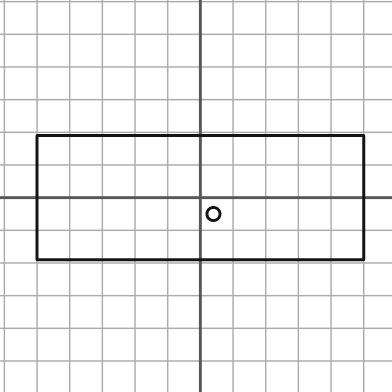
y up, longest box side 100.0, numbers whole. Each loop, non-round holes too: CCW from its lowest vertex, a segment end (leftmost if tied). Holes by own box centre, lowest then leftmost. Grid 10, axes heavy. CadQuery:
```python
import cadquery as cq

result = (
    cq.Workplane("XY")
    .moveTo(-50.0, -19.0)
    .lineTo(50.0, -19.0)
    .lineTo(50.0, 19.0)
    .lineTo(-50.0, 19.0)
    .close()
    .moveTo(4.0, -5.0)
    .circle(2.0)
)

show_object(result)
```